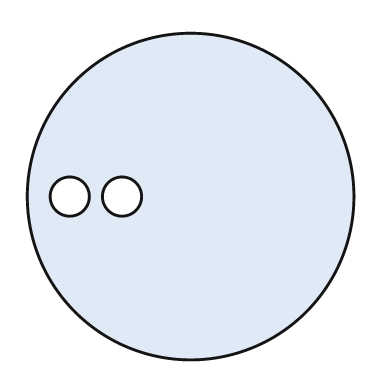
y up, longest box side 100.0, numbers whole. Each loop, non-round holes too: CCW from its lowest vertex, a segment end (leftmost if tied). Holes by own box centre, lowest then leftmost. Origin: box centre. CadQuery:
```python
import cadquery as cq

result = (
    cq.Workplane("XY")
    .moveTo(0.0, 0.0)
    .circle(50.0)
    .moveTo(-37.0, 0.0)
    .circle(6.0)
    .moveTo(-21.0, 0.0)
    .circle(6.0)
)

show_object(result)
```